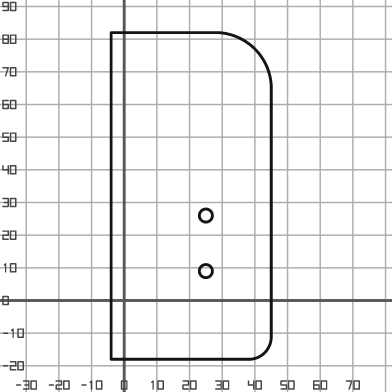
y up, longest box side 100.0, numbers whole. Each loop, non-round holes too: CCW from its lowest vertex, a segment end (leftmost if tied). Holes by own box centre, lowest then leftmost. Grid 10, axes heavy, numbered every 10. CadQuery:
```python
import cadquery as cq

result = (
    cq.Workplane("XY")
    .moveTo(-4.0, -18.0)
    .lineTo(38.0, -18.0)
    .threePointArc((43.0, -16.0), (45.0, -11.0))
    .lineTo(45.0, 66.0)
    .threePointArc((40.0, 77.0), (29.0, 82.0))
    .lineTo(-4.0, 82.0)
    .close()
    .moveTo(25.0, 9.0)
    .circle(2.0)
    .moveTo(25.0, 26.0)
    .circle(2.0)
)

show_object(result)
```